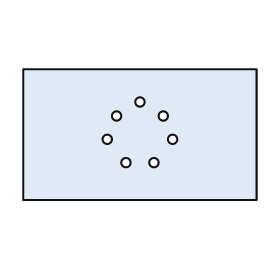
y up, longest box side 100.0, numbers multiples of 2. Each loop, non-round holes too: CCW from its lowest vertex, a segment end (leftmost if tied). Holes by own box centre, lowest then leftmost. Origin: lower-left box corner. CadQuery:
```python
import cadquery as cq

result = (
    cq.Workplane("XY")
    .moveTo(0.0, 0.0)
    .lineTo(100.0, 0.0)
    .lineTo(100.0, 56.0)
    .lineTo(0.0, 56.0)
    .close()
    .moveTo(44.0, 16.0)
    .circle(2.0)
    .moveTo(56.0, 16.0)
    .circle(2.0)
    .moveTo(36.0, 26.0)
    .circle(2.0)
    .moveTo(64.0, 26.0)
    .circle(2.0)
    .moveTo(40.0, 36.0)
    .circle(2.0)
    .moveTo(60.0, 36.0)
    .circle(2.0)
    .moveTo(50.0, 42.0)
    .circle(2.0)
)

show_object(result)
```